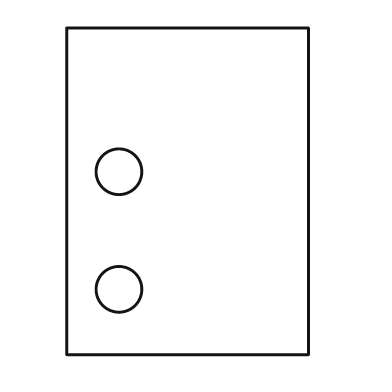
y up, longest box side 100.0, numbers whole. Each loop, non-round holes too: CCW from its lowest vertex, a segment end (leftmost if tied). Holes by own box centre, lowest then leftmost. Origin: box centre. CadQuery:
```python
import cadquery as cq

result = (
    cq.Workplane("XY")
    .moveTo(-37.0, -50.0)
    .lineTo(37.0, -50.0)
    .lineTo(37.0, 50.0)
    .lineTo(-37.0, 50.0)
    .close()
    .moveTo(-21.0, -30.0)
    .circle(7.0)
    .moveTo(-21.0, 6.0)
    .circle(7.0)
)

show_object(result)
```